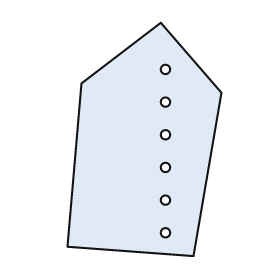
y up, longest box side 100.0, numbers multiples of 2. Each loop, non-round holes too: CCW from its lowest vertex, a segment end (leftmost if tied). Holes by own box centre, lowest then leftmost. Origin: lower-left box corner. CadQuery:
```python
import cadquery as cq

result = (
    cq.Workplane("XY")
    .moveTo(54.0, 0.0)
    .lineTo(66.0, 70.0)
    .lineTo(40.0, 100.0)
    .lineTo(6.0, 74.0)
    .lineTo(0.0, 4.0)
    .close()
    .moveTo(42.0, 10.0)
    .circle(2.0)
    .moveTo(42.0, 24.0)
    .circle(2.0)
    .moveTo(42.0, 38.0)
    .circle(2.0)
    .moveTo(42.0, 52.0)
    .circle(2.0)
    .moveTo(42.0, 66.0)
    .circle(2.0)
    .moveTo(42.0, 80.0)
    .circle(2.0)
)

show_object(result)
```